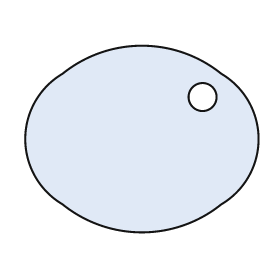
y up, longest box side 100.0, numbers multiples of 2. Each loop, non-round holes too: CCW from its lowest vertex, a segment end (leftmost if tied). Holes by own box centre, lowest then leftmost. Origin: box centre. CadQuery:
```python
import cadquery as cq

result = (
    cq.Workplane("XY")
    .moveTo(-34.0, -28.0)
    .threePointArc((0.0, -40.0), (34.0, -28.0))
    .threePointArc((50.0, 0.0), (34.0, 28.0))
    .threePointArc((0.0, 40.0), (-34.0, 28.0))
    .threePointArc((-50.0, 0.0), (-34.0, -28.0))
    .close()
    .moveTo(26.0, 18.0)
    .circle(6.0)
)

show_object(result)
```